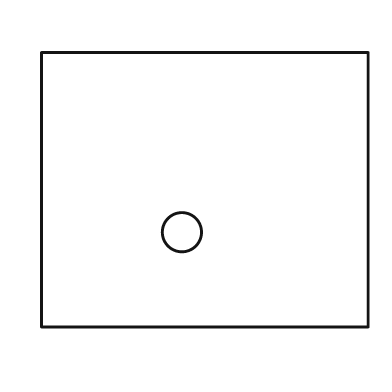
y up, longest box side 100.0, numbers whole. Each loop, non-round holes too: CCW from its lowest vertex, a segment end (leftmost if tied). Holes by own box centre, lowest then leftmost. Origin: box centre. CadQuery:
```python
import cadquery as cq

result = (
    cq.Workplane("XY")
    .moveTo(-50.0, -42.0)
    .lineTo(50.0, -42.0)
    .lineTo(50.0, 42.0)
    .lineTo(-50.0, 42.0)
    .close()
    .moveTo(-7.0, -13.0)
    .circle(6.0)
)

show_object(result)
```